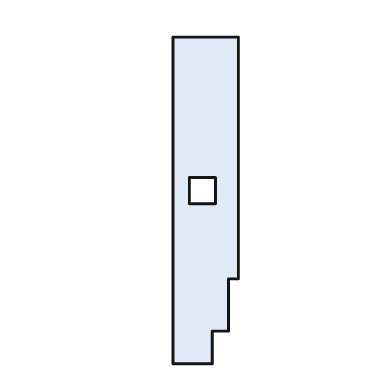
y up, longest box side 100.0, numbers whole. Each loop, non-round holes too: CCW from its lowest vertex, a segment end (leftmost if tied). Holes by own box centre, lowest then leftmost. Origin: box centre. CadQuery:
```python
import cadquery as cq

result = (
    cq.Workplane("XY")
    .moveTo(-10.0, -50.0)
    .lineTo(2.0, -50.0)
    .lineTo(2.0, -40.0)
    .lineTo(7.0, -40.0)
    .lineTo(7.0, -24.0)
    .lineTo(10.0, -24.0)
    .lineTo(10.0, 50.0)
    .lineTo(-10.0, 50.0)
    .close()
    .moveTo(-5.0, -1.0)
    .lineTo(3.0, -1.0)
    .lineTo(3.0, 7.0)
    .lineTo(-5.0, 7.0)
    .close()
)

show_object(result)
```